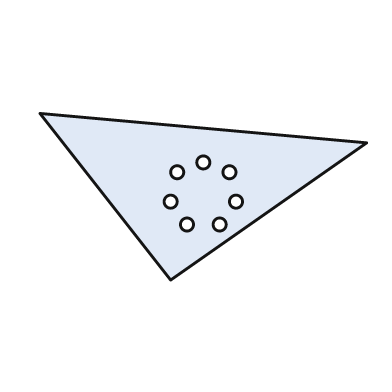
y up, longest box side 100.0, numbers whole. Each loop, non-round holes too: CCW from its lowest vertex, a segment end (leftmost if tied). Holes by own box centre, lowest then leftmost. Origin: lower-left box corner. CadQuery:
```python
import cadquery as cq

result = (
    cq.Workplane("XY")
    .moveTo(40.0, 0.0)
    .lineTo(100.0, 42.0)
    .lineTo(0.0, 51.0)
    .close()
    .moveTo(45.0, 17.0)
    .circle(2.0)
    .moveTo(55.0, 17.0)
    .circle(2.0)
    .moveTo(40.0, 24.0)
    .circle(2.0)
    .moveTo(60.0, 24.0)
    .circle(2.0)
    .moveTo(42.0, 33.0)
    .circle(2.0)
    .moveTo(58.0, 33.0)
    .circle(2.0)
    .moveTo(50.0, 36.0)
    .circle(2.0)
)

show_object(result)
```